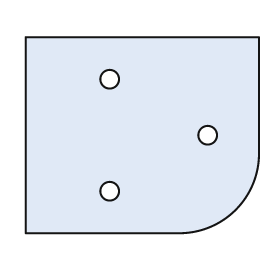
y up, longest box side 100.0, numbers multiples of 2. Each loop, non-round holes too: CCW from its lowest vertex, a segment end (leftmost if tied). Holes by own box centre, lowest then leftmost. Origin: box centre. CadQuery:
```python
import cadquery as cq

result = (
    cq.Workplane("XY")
    .moveTo(-50.0, -42.0)
    .lineTo(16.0, -42.0)
    .threePointArc((40.0, -32.0), (50.0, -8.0))
    .lineTo(50.0, 42.0)
    .lineTo(-50.0, 42.0)
    .close()
    .moveTo(-14.0, -24.0)
    .circle(4.0)
    .moveTo(28.0, 0.0)
    .circle(4.0)
    .moveTo(-14.0, 24.0)
    .circle(4.0)
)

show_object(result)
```